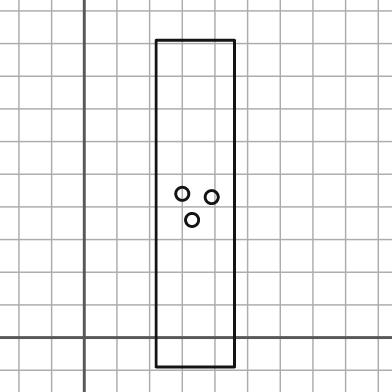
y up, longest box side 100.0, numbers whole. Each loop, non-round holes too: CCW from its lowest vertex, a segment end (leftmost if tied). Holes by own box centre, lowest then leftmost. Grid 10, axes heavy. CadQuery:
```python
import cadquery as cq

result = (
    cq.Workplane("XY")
    .moveTo(22.0, -9.0)
    .lineTo(46.0, -9.0)
    .lineTo(46.0, 91.0)
    .lineTo(22.0, 91.0)
    .close()
    .moveTo(33.0, 36.0)
    .circle(2.0)
    .moveTo(39.0, 43.0)
    .circle(2.0)
    .moveTo(30.0, 44.0)
    .circle(2.0)
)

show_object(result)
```